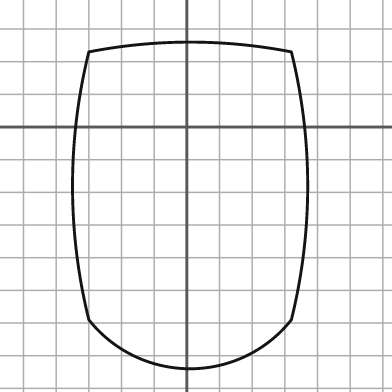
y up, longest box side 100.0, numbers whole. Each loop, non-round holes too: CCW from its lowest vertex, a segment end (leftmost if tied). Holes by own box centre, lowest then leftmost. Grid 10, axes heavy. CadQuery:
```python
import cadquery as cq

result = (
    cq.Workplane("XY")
    .moveTo(-30.0, -59.0)
    .threePointArc((1.0, -74.0), (32.0, -59.0))
    .threePointArc((37.0, -18.0), (32.0, 23.0))
    .threePointArc((1.0, 26.0), (-30.0, 23.0))
    .threePointArc((-35.0, -18.0), (-30.0, -59.0))
    .close()
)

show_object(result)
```